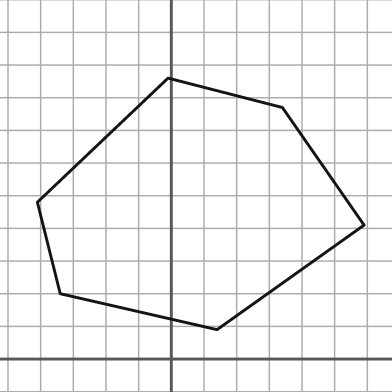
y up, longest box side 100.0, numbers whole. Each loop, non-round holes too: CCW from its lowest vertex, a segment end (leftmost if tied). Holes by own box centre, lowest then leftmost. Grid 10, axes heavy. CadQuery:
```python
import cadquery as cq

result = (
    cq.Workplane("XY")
    .moveTo(14.0, 9.0)
    .lineTo(59.0, 41.0)
    .lineTo(34.0, 77.0)
    .lineTo(-1.0, 86.0)
    .lineTo(-41.0, 48.0)
    .lineTo(-34.0, 20.0)
    .close()
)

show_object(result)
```